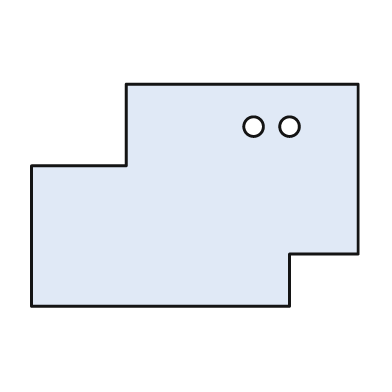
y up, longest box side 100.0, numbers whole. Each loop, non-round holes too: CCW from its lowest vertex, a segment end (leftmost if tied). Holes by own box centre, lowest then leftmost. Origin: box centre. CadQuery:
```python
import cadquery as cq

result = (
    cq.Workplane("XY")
    .moveTo(-50.0, -34.0)
    .lineTo(29.0, -34.0)
    .lineTo(29.0, -18.0)
    .lineTo(50.0, -18.0)
    .lineTo(50.0, 34.0)
    .lineTo(-21.0, 34.0)
    .lineTo(-21.0, 9.0)
    .lineTo(-50.0, 9.0)
    .close()
    .moveTo(18.0, 21.0)
    .circle(3.0)
    .moveTo(29.0, 21.0)
    .circle(3.0)
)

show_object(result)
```